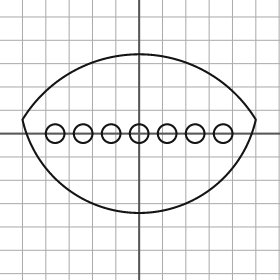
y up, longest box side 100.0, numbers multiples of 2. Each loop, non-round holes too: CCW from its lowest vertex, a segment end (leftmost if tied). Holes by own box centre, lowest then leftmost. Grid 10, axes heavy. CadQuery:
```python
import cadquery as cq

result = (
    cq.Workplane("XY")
    .moveTo(-50.0, 6.0)
    .threePointArc((0.0, -34.0), (50.0, 6.0))
    .threePointArc((0.0, 34.0), (-50.0, 6.0))
    .close()
    .moveTo(-36.0, 0.0)
    .circle(4.0)
    .moveTo(-24.0, 0.0)
    .circle(4.0)
    .moveTo(-12.0, 0.0)
    .circle(4.0)
    .moveTo(0.0, 0.0)
    .circle(4.0)
    .moveTo(12.0, 0.0)
    .circle(4.0)
    .moveTo(24.0, 0.0)
    .circle(4.0)
    .moveTo(36.0, 0.0)
    .circle(4.0)
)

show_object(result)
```